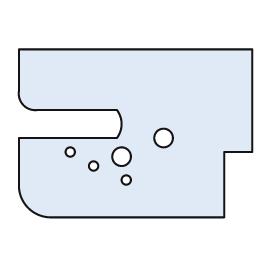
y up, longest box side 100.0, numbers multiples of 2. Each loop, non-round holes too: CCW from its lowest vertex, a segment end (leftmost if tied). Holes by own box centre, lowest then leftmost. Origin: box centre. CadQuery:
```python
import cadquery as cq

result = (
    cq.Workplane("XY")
    .moveTo(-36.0, -36.0)
    .lineTo(38.0, -36.0)
    .lineTo(38.0, -8.0)
    .lineTo(50.0, -8.0)
    .lineTo(50.0, 36.0)
    .lineTo(-50.0, 36.0)
    .lineTo(-50.0, 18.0)
    .threePointArc((-48.0, 12.0), (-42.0, 10.0))
    .lineTo(-8.0, 10.0)
    .threePointArc((-6.0, 4.0), (-8.0, -2.0))
    .lineTo(-50.0, -2.0)
    .lineTo(-50.0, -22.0)
    .threePointArc((-46.0, -32.0), (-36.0, -36.0))
    .close()
    .moveTo(-4.0, -20.0)
    .circle(2.0)
    .moveTo(-18.0, -14.0)
    .circle(2.0)
    .moveTo(-6.0, -10.0)
    .circle(4.0)
    .moveTo(-28.0, -8.0)
    .circle(2.0)
    .moveTo(12.0, -2.0)
    .circle(4.0)
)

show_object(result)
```